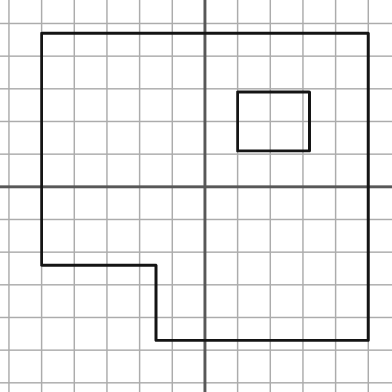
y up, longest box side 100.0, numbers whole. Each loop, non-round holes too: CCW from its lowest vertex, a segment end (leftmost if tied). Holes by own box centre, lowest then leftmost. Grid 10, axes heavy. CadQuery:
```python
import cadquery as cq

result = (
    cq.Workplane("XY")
    .moveTo(-15.0, -47.0)
    .lineTo(50.0, -47.0)
    .lineTo(50.0, 47.0)
    .lineTo(-50.0, 47.0)
    .lineTo(-50.0, -24.0)
    .lineTo(-15.0, -24.0)
    .close()
    .moveTo(10.0, 11.0)
    .lineTo(32.0, 11.0)
    .lineTo(32.0, 29.0)
    .lineTo(10.0, 29.0)
    .close()
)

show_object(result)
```